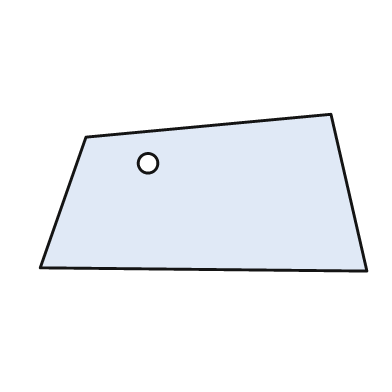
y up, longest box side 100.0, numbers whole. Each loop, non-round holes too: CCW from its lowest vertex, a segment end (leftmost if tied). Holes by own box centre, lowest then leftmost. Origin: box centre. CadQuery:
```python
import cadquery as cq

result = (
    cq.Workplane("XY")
    .moveTo(50.0, -24.0)
    .lineTo(39.0, 24.0)
    .lineTo(-36.0, 17.0)
    .lineTo(-50.0, -23.0)
    .close()
    .moveTo(-17.0, 9.0)
    .circle(3.0)
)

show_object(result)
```